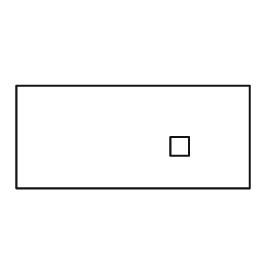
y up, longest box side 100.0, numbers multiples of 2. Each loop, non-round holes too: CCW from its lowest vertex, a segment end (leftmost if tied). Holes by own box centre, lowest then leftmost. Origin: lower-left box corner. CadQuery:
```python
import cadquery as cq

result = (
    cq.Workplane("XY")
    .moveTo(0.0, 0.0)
    .lineTo(100.0, 0.0)
    .lineTo(100.0, 44.0)
    .lineTo(0.0, 44.0)
    .close()
    .moveTo(66.0, 14.0)
    .lineTo(74.0, 14.0)
    .lineTo(74.0, 22.0)
    .lineTo(66.0, 22.0)
    .close()
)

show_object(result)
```